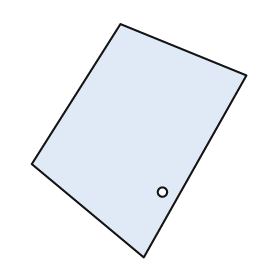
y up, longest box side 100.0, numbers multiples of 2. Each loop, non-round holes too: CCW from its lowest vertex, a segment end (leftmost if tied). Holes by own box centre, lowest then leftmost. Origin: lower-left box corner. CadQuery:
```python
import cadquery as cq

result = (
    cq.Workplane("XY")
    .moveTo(48.0, 0.0)
    .lineTo(92.0, 78.0)
    .lineTo(38.0, 100.0)
    .lineTo(0.0, 40.0)
    .close()
    .moveTo(56.0, 28.0)
    .circle(2.0)
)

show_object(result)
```